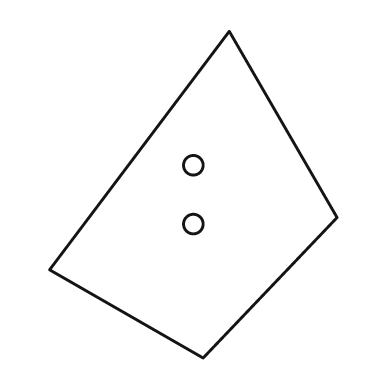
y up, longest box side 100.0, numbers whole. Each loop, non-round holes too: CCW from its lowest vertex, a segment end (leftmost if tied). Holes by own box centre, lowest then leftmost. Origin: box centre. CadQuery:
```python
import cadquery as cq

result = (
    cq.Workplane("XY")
    .moveTo(3.0, -50.0)
    .lineTo(44.0, -7.0)
    .lineTo(11.0, 50.0)
    .lineTo(-44.0, -23.0)
    .close()
    .moveTo(0.0, -9.0)
    .circle(3.0)
    .moveTo(0.0, 9.0)
    .circle(3.0)
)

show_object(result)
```